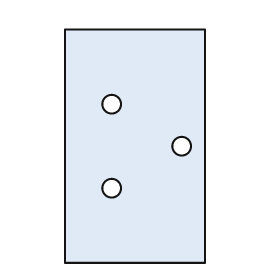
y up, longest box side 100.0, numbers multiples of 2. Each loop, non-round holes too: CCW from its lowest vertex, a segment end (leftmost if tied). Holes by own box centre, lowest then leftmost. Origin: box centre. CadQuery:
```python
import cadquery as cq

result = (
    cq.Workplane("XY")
    .moveTo(-30.0, -50.0)
    .lineTo(30.0, -50.0)
    .lineTo(30.0, 50.0)
    .lineTo(-30.0, 50.0)
    .close()
    .moveTo(-10.0, -18.0)
    .circle(4.0)
    .moveTo(20.0, 0.0)
    .circle(4.0)
    .moveTo(-10.0, 18.0)
    .circle(4.0)
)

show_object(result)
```